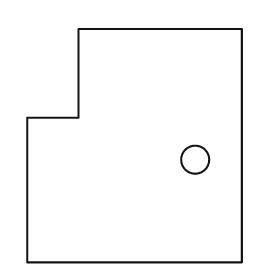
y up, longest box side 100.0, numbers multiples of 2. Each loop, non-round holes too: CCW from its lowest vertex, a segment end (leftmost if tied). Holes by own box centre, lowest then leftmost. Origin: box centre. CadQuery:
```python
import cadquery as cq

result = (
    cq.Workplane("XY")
    .moveTo(-46.0, -50.0)
    .lineTo(46.0, -50.0)
    .lineTo(46.0, 50.0)
    .lineTo(-24.0, 50.0)
    .lineTo(-24.0, 12.0)
    .lineTo(-46.0, 12.0)
    .close()
    .moveTo(26.0, -6.0)
    .circle(6.0)
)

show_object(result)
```